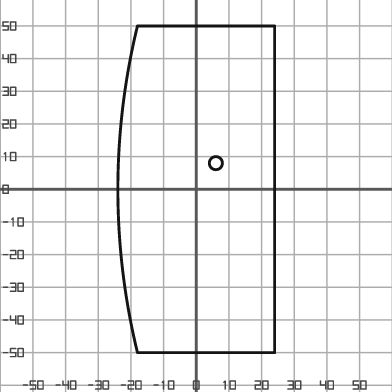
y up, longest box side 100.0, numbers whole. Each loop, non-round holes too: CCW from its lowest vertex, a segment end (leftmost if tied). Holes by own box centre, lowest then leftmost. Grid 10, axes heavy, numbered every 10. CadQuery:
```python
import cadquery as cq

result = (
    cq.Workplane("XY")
    .moveTo(-18.0, -50.0)
    .lineTo(24.0, -50.0)
    .lineTo(24.0, 50.0)
    .lineTo(-18.0, 50.0)
    .threePointArc((-24.0, 0.0), (-18.0, -50.0))
    .close()
    .moveTo(6.0, 8.0)
    .circle(2.0)
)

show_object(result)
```